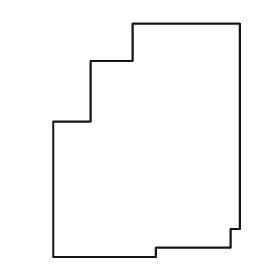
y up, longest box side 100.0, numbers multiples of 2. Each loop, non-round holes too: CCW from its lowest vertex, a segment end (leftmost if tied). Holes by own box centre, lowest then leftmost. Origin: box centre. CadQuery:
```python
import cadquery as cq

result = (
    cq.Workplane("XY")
    .moveTo(-40.0, -50.0)
    .lineTo(4.0, -50.0)
    .lineTo(4.0, -46.0)
    .lineTo(36.0, -46.0)
    .lineTo(36.0, -38.0)
    .lineTo(40.0, -38.0)
    .lineTo(40.0, 50.0)
    .lineTo(-6.0, 50.0)
    .lineTo(-6.0, 34.0)
    .lineTo(-24.0, 34.0)
    .lineTo(-24.0, 8.0)
    .lineTo(-40.0, 8.0)
    .close()
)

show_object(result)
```